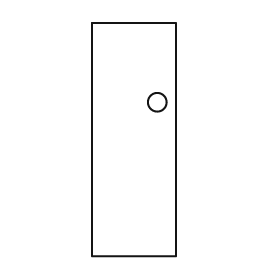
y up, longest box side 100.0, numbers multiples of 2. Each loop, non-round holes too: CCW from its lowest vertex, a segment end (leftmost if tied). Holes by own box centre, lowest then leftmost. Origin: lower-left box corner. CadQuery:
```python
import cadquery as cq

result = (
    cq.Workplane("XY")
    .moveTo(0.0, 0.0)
    .lineTo(36.0, 0.0)
    .lineTo(36.0, 100.0)
    .lineTo(0.0, 100.0)
    .close()
    .moveTo(28.0, 66.0)
    .circle(4.0)
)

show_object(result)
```